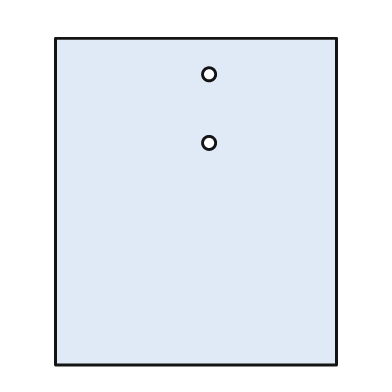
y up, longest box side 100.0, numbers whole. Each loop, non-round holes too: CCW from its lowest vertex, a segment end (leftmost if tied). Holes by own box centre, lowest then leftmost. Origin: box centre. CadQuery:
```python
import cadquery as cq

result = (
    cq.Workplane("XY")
    .moveTo(-43.0, -50.0)
    .lineTo(43.0, -50.0)
    .lineTo(43.0, 50.0)
    .lineTo(-43.0, 50.0)
    .close()
    .moveTo(4.0, 18.0)
    .circle(2.0)
    .moveTo(4.0, 39.0)
    .circle(2.0)
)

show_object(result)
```